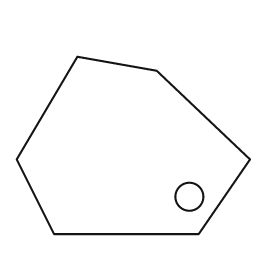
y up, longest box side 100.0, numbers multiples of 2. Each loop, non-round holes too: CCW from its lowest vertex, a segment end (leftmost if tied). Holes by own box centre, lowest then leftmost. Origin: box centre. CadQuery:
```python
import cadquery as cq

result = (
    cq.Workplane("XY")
    .moveTo(-34.0, -38.0)
    .lineTo(28.0, -38.0)
    .lineTo(50.0, -6.0)
    .lineTo(10.0, 32.0)
    .lineTo(-24.0, 38.0)
    .lineTo(-50.0, -6.0)
    .close()
    .moveTo(24.0, -22.0)
    .circle(6.0)
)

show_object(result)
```